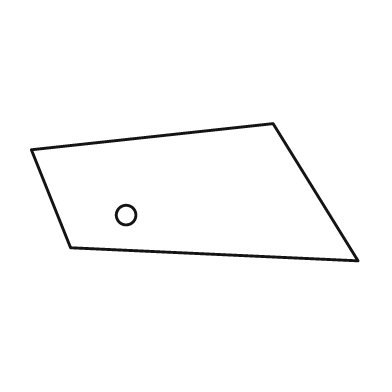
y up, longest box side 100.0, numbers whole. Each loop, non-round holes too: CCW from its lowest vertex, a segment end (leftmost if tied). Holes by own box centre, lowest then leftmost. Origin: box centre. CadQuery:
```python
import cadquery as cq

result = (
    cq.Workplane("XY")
    .moveTo(50.0, -21.0)
    .lineTo(24.0, 21.0)
    .lineTo(-50.0, 13.0)
    .lineTo(-38.0, -17.0)
    .close()
    .moveTo(-21.0, -7.0)
    .circle(3.0)
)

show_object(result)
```